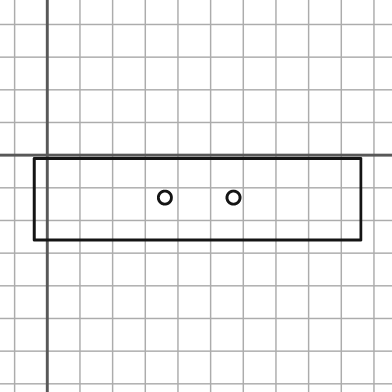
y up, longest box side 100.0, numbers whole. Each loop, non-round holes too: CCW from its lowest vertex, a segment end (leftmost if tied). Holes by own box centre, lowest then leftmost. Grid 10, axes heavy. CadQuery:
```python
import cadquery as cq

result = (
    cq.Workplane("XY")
    .moveTo(-4.0, -26.0)
    .lineTo(96.0, -26.0)
    .lineTo(96.0, -1.0)
    .lineTo(-4.0, -1.0)
    .close()
    .moveTo(36.0, -13.0)
    .circle(2.0)
    .moveTo(57.0, -13.0)
    .circle(2.0)
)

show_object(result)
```